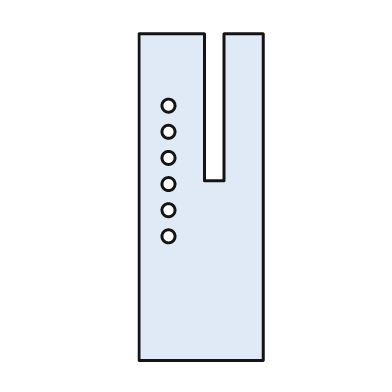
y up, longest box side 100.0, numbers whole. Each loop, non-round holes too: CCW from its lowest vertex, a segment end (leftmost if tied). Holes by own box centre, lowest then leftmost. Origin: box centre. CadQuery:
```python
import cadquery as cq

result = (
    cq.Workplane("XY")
    .moveTo(-19.0, -50.0)
    .lineTo(19.0, -50.0)
    .lineTo(19.0, 50.0)
    .lineTo(7.0, 50.0)
    .lineTo(7.0, 5.0)
    .lineTo(1.0, 5.0)
    .lineTo(1.0, 50.0)
    .lineTo(-19.0, 50.0)
    .close()
    .moveTo(-10.0, -12.0)
    .circle(2.0)
    .moveTo(-10.0, -4.0)
    .circle(2.0)
    .moveTo(-10.0, 4.0)
    .circle(2.0)
    .moveTo(-10.0, 12.0)
    .circle(2.0)
    .moveTo(-10.0, 20.0)
    .circle(2.0)
    .moveTo(-10.0, 28.0)
    .circle(2.0)
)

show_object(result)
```